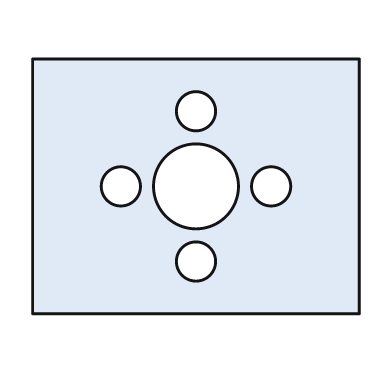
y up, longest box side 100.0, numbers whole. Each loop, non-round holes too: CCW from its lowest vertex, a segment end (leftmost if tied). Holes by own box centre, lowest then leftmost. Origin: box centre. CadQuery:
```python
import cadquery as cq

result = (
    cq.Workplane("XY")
    .moveTo(-50.0, -39.0)
    .lineTo(50.0, -39.0)
    .lineTo(50.0, 39.0)
    .lineTo(-50.0, 39.0)
    .close()
    .moveTo(0.0, -23.0)
    .circle(6.0)
    .moveTo(-23.0, 0.0)
    .circle(6.0)
    .moveTo(0.0, 0.0)
    .circle(13.0)
    .moveTo(23.0, 0.0)
    .circle(6.0)
    .moveTo(0.0, 23.0)
    .circle(6.0)
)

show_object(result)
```